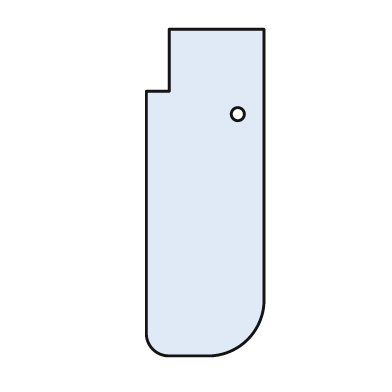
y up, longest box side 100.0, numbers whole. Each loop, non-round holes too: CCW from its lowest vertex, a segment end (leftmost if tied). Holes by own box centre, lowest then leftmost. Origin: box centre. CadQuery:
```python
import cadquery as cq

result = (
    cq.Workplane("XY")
    .moveTo(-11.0, -50.0)
    .lineTo(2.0, -50.0)
    .threePointArc((13.0, -45.0), (18.0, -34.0))
    .lineTo(18.0, 50.0)
    .lineTo(-11.0, 50.0)
    .lineTo(-11.0, 31.0)
    .lineTo(-18.0, 31.0)
    .lineTo(-18.0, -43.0)
    .threePointArc((-16.0, -48.0), (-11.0, -50.0))
    .close()
    .moveTo(10.0, 24.0)
    .circle(2.0)
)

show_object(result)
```